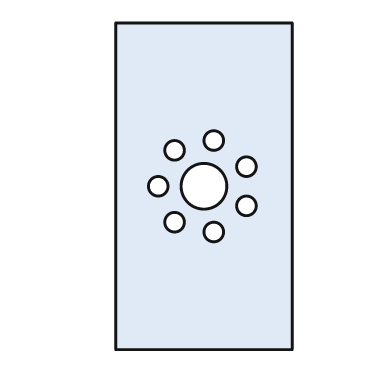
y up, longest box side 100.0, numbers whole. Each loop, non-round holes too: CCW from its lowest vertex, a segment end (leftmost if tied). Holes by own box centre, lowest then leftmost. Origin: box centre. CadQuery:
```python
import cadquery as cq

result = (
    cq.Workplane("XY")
    .moveTo(-27.0, -50.0)
    .lineTo(27.0, -50.0)
    .lineTo(27.0, 50.0)
    .lineTo(-27.0, 50.0)
    .close()
    .moveTo(3.0, -14.0)
    .circle(3.0)
    .moveTo(-9.0, -11.0)
    .circle(3.0)
    .moveTo(13.0, -6.0)
    .circle(3.0)
    .moveTo(-14.0, 0.0)
    .circle(3.0)
    .moveTo(0.0, 0.0)
    .circle(7.0)
    .moveTo(13.0, 6.0)
    .circle(3.0)
    .moveTo(-9.0, 11.0)
    .circle(3.0)
    .moveTo(3.0, 14.0)
    .circle(3.0)
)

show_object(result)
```